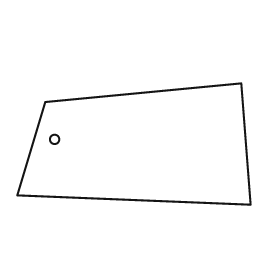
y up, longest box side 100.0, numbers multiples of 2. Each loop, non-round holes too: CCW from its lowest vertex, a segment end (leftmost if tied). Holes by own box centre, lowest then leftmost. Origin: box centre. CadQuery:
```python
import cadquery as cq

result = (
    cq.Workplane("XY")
    .moveTo(50.0, -26.0)
    .lineTo(46.0, 26.0)
    .lineTo(-38.0, 18.0)
    .lineTo(-50.0, -22.0)
    .close()
    .moveTo(-34.0, 2.0)
    .circle(2.0)
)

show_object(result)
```